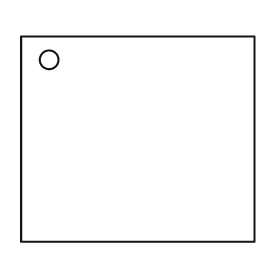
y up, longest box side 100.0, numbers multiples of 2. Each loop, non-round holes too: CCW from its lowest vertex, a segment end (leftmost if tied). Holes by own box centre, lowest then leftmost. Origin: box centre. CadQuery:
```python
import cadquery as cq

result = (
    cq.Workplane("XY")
    .moveTo(-50.0, -44.0)
    .lineTo(50.0, -44.0)
    .lineTo(50.0, 44.0)
    .lineTo(-50.0, 44.0)
    .close()
    .moveTo(-38.0, 34.0)
    .circle(4.0)
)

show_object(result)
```